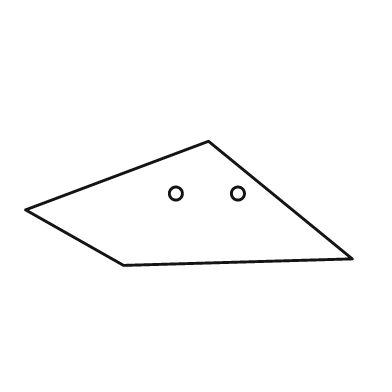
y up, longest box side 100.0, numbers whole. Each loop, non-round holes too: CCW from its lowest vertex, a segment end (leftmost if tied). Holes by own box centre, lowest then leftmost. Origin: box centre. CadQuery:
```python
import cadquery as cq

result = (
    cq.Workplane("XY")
    .moveTo(-20.0, -19.0)
    .lineTo(50.0, -17.0)
    .lineTo(6.0, 19.0)
    .lineTo(-50.0, -2.0)
    .close()
    .moveTo(-4.0, 3.0)
    .circle(2.0)
    .moveTo(15.0, 3.0)
    .circle(2.0)
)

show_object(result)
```